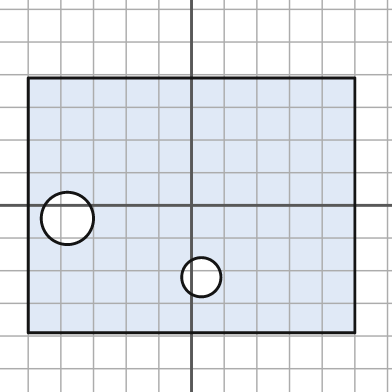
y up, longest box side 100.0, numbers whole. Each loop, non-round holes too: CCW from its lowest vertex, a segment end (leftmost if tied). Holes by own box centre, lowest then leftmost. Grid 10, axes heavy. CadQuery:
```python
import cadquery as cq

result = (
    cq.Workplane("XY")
    .moveTo(-50.0, -39.0)
    .lineTo(50.0, -39.0)
    .lineTo(50.0, 39.0)
    .lineTo(-50.0, 39.0)
    .close()
    .moveTo(3.0, -22.0)
    .circle(6.0)
    .moveTo(-38.0, -4.0)
    .circle(8.0)
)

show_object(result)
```